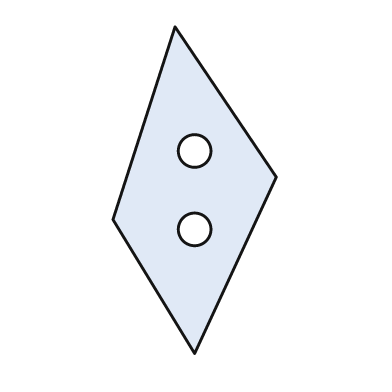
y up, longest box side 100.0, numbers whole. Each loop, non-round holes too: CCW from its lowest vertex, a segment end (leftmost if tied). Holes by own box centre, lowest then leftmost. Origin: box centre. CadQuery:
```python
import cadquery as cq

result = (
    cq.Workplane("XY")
    .moveTo(0.0, -50.0)
    .lineTo(25.0, 4.0)
    .lineTo(-6.0, 50.0)
    .lineTo(-25.0, -9.0)
    .close()
    .moveTo(0.0, -12.0)
    .circle(5.0)
    .moveTo(0.0, 12.0)
    .circle(5.0)
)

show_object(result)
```